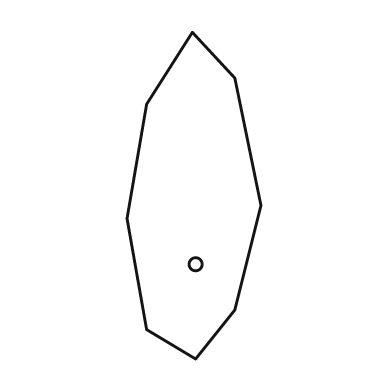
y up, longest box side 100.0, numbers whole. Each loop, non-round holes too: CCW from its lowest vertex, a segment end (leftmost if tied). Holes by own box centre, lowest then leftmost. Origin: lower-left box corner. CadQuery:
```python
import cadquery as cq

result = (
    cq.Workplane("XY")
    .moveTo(21.0, 0.0)
    .lineTo(33.0, 15.0)
    .lineTo(41.0, 47.0)
    .lineTo(33.0, 86.0)
    .lineTo(20.0, 100.0)
    .lineTo(6.0, 78.0)
    .lineTo(0.0, 43.0)
    .lineTo(6.0, 9.0)
    .close()
    .moveTo(21.0, 29.0)
    .circle(2.0)
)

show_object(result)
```